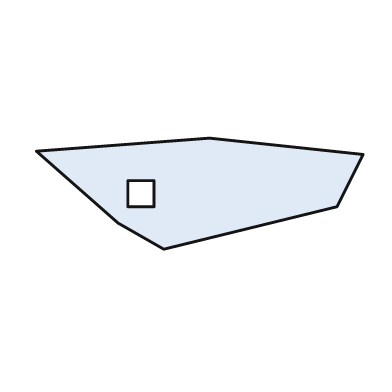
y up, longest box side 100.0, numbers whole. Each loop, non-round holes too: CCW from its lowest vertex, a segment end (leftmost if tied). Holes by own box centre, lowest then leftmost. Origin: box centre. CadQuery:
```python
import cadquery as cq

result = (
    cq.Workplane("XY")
    .moveTo(-11.0, -17.0)
    .lineTo(42.0, -4.0)
    .lineTo(50.0, 12.0)
    .lineTo(3.0, 17.0)
    .lineTo(-50.0, 13.0)
    .lineTo(-25.0, -9.0)
    .close()
    .moveTo(-22.0, -4.0)
    .lineTo(-14.0, -4.0)
    .lineTo(-14.0, 4.0)
    .lineTo(-22.0, 4.0)
    .close()
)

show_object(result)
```